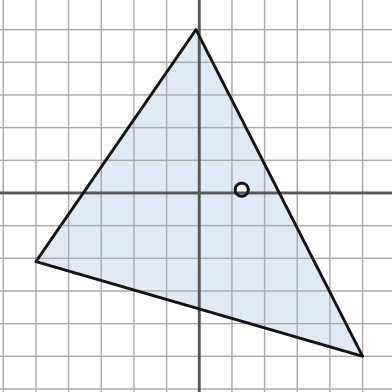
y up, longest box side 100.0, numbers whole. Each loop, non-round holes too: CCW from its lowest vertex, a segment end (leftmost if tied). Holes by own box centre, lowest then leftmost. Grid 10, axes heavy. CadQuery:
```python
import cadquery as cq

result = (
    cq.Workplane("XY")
    .moveTo(50.0, -50.0)
    .lineTo(-1.0, 50.0)
    .lineTo(-50.0, -21.0)
    .close()
    .moveTo(13.0, 1.0)
    .circle(2.0)
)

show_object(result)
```